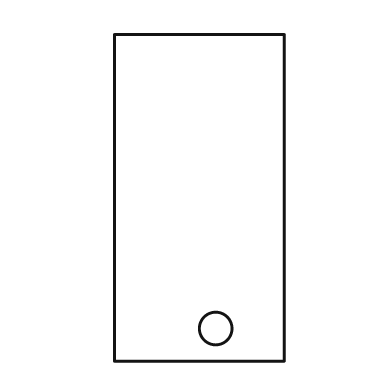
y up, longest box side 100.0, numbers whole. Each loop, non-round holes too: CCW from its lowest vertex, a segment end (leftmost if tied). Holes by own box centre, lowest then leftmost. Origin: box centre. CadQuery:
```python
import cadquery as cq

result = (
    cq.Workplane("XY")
    .moveTo(-26.0, -50.0)
    .lineTo(26.0, -50.0)
    .lineTo(26.0, 50.0)
    .lineTo(-26.0, 50.0)
    .close()
    .moveTo(5.0, -40.0)
    .circle(5.0)
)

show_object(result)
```